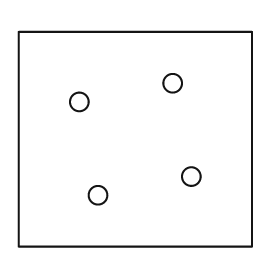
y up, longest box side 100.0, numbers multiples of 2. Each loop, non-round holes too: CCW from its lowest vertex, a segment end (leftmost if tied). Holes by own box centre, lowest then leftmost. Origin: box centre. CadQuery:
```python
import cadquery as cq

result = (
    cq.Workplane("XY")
    .moveTo(-50.0, -46.0)
    .lineTo(50.0, -46.0)
    .lineTo(50.0, 46.0)
    .lineTo(-50.0, 46.0)
    .close()
    .moveTo(-16.0, -24.0)
    .circle(4.0)
    .moveTo(24.0, -16.0)
    .circle(4.0)
    .moveTo(-24.0, 16.0)
    .circle(4.0)
    .moveTo(16.0, 24.0)
    .circle(4.0)
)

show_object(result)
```